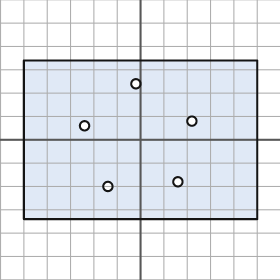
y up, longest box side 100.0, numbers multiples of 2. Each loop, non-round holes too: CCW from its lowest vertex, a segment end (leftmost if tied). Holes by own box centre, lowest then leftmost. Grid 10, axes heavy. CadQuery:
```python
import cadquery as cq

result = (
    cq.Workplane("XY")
    .moveTo(-50.0, -34.0)
    .lineTo(50.0, -34.0)
    .lineTo(50.0, 34.0)
    .lineTo(-50.0, 34.0)
    .close()
    .moveTo(-14.0, -20.0)
    .circle(2.0)
    .moveTo(16.0, -18.0)
    .circle(2.0)
    .moveTo(-24.0, 6.0)
    .circle(2.0)
    .moveTo(22.0, 8.0)
    .circle(2.0)
    .moveTo(-2.0, 24.0)
    .circle(2.0)
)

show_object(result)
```